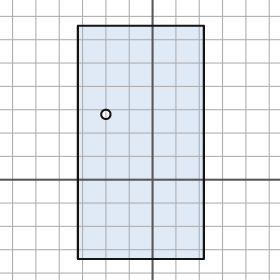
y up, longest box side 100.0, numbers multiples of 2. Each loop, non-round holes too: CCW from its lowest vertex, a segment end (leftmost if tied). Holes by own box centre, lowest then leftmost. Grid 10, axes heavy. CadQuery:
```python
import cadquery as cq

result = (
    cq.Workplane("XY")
    .moveTo(-32.0, -34.0)
    .lineTo(22.0, -34.0)
    .lineTo(22.0, 66.0)
    .lineTo(-32.0, 66.0)
    .close()
    .moveTo(-20.0, 28.0)
    .circle(2.0)
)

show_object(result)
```